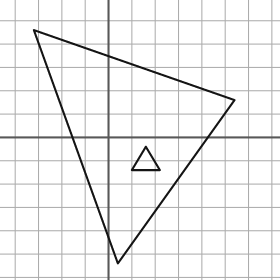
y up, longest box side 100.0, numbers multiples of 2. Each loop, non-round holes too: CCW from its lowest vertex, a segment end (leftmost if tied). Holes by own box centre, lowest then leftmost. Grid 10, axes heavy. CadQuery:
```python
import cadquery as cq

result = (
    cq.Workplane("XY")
    .moveTo(4.0, -54.0)
    .lineTo(54.0, 16.0)
    .lineTo(-32.0, 46.0)
    .close()
    .moveTo(10.0, -14.0)
    .lineTo(22.0, -14.0)
    .lineTo(16.0, -4.0)
    .close()
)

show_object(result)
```